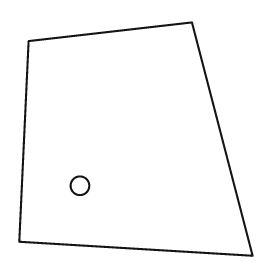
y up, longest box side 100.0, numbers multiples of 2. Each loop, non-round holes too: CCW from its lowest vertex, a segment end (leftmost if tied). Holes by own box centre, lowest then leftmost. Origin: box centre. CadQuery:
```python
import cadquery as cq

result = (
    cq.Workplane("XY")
    .moveTo(50.0, -50.0)
    .lineTo(24.0, 50.0)
    .lineTo(-46.0, 42.0)
    .lineTo(-50.0, -44.0)
    .close()
    .moveTo(-24.0, -20.0)
    .circle(4.0)
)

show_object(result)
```